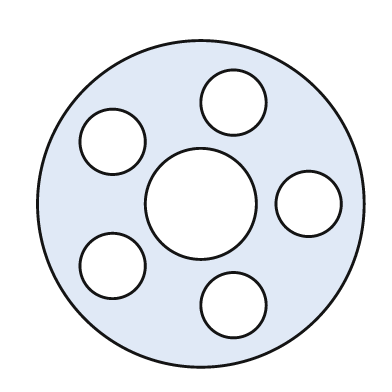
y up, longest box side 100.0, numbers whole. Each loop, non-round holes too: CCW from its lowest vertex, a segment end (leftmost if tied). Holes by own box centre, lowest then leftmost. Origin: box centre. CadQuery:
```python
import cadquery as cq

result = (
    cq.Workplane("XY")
    .moveTo(0.0, 0.0)
    .circle(50.0)
    .moveTo(10.0, -31.0)
    .circle(10.0)
    .moveTo(-27.0, -19.0)
    .circle(10.0)
    .moveTo(0.0, 0.0)
    .circle(17.0)
    .moveTo(33.0, 0.0)
    .circle(10.0)
    .moveTo(-27.0, 19.0)
    .circle(10.0)
    .moveTo(10.0, 31.0)
    .circle(10.0)
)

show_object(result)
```